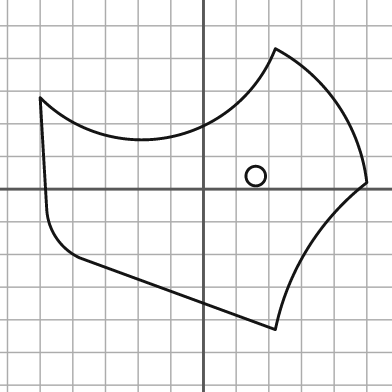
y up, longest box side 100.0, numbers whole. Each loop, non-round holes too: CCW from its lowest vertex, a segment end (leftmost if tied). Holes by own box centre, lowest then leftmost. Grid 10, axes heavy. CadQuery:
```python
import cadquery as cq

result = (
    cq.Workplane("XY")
    .moveTo(22.0, -43.0)
    .threePointArc((32.0, -18.0), (50.0, 2.0))
    .threePointArc((41.0, 26.0), (22.0, 43.0))
    .threePointArc((-10.0, 16.0), (-50.0, 28.0))
    .lineTo(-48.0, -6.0)
    .threePointArc((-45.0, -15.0), (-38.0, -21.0))
    .close()
    .moveTo(16.0, 4.0)
    .circle(3.0)
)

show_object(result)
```